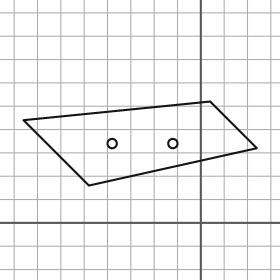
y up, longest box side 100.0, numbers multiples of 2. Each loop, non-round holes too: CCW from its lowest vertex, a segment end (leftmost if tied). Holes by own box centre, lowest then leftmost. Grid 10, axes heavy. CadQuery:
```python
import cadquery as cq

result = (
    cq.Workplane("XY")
    .moveTo(-48.0, 16.0)
    .lineTo(24.0, 32.0)
    .lineTo(4.0, 52.0)
    .lineTo(-76.0, 44.0)
    .close()
    .moveTo(-38.0, 34.0)
    .circle(2.0)
    .moveTo(-12.0, 34.0)
    .circle(2.0)
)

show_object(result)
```